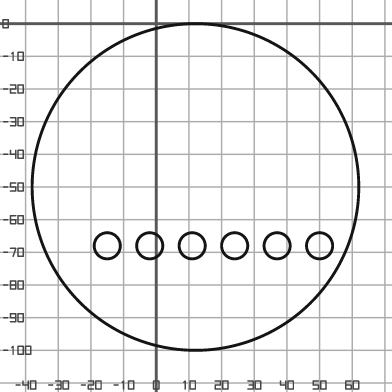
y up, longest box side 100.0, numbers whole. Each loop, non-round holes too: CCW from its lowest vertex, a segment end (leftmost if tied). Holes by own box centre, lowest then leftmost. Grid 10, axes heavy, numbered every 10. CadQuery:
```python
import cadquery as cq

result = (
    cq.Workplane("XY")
    .moveTo(12.0, -50.0)
    .circle(50.0)
    .moveTo(-15.0, -68.0)
    .circle(4.0)
    .moveTo(-2.0, -68.0)
    .circle(4.0)
    .moveTo(11.0, -68.0)
    .circle(4.0)
    .moveTo(24.0, -68.0)
    .circle(4.0)
    .moveTo(37.0, -68.0)
    .circle(4.0)
    .moveTo(50.0, -68.0)
    .circle(4.0)
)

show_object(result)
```